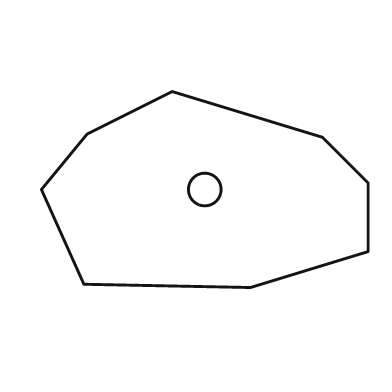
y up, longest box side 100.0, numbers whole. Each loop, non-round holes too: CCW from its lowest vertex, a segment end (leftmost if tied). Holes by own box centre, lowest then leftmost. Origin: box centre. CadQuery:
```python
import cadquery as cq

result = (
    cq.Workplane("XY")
    .moveTo(14.0, -30.0)
    .lineTo(50.0, -19.0)
    .lineTo(50.0, 2.0)
    .lineTo(36.0, 16.0)
    .lineTo(-10.0, 30.0)
    .lineTo(-36.0, 17.0)
    .lineTo(-50.0, 0.0)
    .lineTo(-37.0, -29.0)
    .close()
    .moveTo(0.0, 0.0)
    .circle(5.0)
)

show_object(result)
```